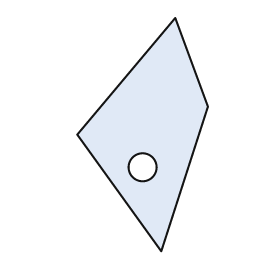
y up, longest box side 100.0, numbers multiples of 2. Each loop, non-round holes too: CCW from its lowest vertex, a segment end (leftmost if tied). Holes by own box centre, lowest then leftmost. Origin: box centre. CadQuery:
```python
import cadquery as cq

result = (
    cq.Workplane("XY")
    .moveTo(8.0, -50.0)
    .lineTo(28.0, 12.0)
    .lineTo(14.0, 50.0)
    .lineTo(-28.0, 0.0)
    .close()
    .moveTo(0.0, -14.0)
    .circle(6.0)
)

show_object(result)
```